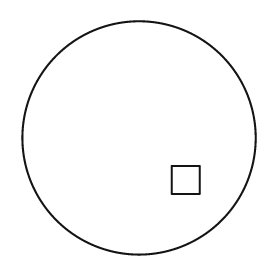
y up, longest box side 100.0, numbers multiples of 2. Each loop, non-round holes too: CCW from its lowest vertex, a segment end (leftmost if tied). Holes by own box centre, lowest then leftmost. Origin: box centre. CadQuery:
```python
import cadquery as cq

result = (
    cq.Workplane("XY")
    .moveTo(0.0, 0.0)
    .circle(50.0)
    .moveTo(14.0, -24.0)
    .lineTo(26.0, -24.0)
    .lineTo(26.0, -12.0)
    .lineTo(14.0, -12.0)
    .close()
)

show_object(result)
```